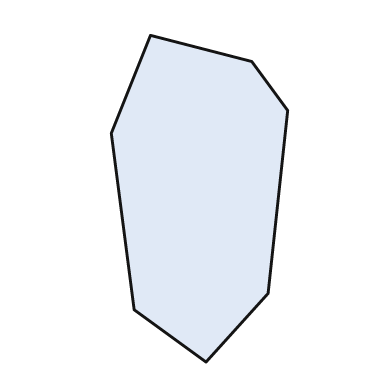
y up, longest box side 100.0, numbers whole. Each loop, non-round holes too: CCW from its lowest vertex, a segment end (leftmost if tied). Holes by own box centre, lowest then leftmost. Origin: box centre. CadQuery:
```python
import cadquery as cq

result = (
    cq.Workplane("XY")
    .moveTo(2.0, -50.0)
    .lineTo(21.0, -29.0)
    .lineTo(27.0, 27.0)
    .lineTo(16.0, 42.0)
    .lineTo(-15.0, 50.0)
    .lineTo(-27.0, 20.0)
    .lineTo(-20.0, -34.0)
    .close()
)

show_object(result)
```